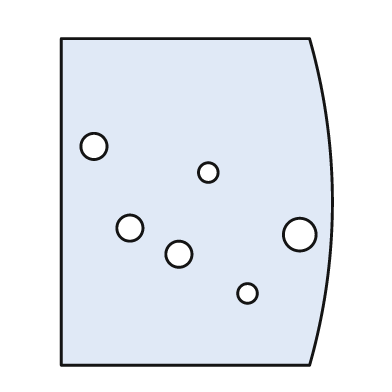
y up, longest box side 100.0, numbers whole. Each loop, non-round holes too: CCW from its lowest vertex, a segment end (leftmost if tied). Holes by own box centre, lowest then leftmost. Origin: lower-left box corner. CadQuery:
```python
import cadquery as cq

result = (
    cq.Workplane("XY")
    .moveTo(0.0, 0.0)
    .lineTo(76.0, 0.0)
    .threePointArc((83.0, 50.0), (76.0, 100.0))
    .lineTo(0.0, 100.0)
    .close()
    .moveTo(57.0, 22.0)
    .circle(3.0)
    .moveTo(36.0, 34.0)
    .circle(4.0)
    .moveTo(73.0, 40.0)
    .circle(5.0)
    .moveTo(21.0, 42.0)
    .circle(4.0)
    .moveTo(45.0, 59.0)
    .circle(3.0)
    .moveTo(10.0, 67.0)
    .circle(4.0)
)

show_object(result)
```